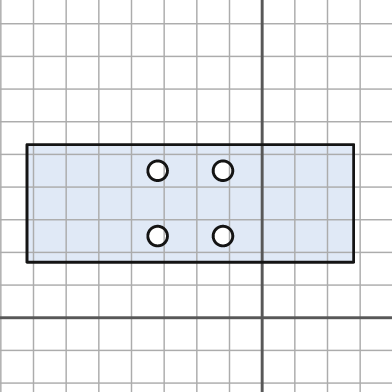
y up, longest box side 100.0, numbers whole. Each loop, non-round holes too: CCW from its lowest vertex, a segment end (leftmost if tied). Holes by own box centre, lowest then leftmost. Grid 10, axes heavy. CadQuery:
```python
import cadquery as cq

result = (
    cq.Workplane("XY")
    .moveTo(-72.0, 17.0)
    .lineTo(28.0, 17.0)
    .lineTo(28.0, 53.0)
    .lineTo(-72.0, 53.0)
    .close()
    .moveTo(-32.0, 25.0)
    .circle(3.0)
    .moveTo(-12.0, 25.0)
    .circle(3.0)
    .moveTo(-32.0, 45.0)
    .circle(3.0)
    .moveTo(-12.0, 45.0)
    .circle(3.0)
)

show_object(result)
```